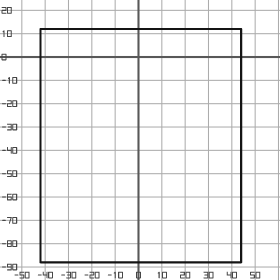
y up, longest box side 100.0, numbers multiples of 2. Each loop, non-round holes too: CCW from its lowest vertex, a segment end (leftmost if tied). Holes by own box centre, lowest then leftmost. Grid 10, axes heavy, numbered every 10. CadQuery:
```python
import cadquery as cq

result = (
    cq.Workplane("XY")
    .moveTo(-42.0, -88.0)
    .lineTo(44.0, -88.0)
    .lineTo(44.0, 12.0)
    .lineTo(-42.0, 12.0)
    .close()
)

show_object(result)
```